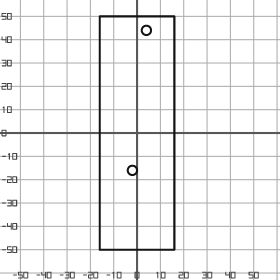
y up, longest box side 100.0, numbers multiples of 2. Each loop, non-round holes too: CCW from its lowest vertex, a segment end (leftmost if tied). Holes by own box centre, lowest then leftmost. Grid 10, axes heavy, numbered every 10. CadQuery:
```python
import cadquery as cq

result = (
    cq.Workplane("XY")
    .moveTo(-16.0, -50.0)
    .lineTo(16.0, -50.0)
    .lineTo(16.0, 50.0)
    .lineTo(-16.0, 50.0)
    .close()
    .moveTo(-2.0, -16.0)
    .circle(2.0)
    .moveTo(4.0, 44.0)
    .circle(2.0)
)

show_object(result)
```